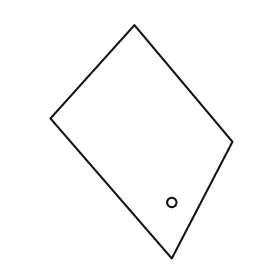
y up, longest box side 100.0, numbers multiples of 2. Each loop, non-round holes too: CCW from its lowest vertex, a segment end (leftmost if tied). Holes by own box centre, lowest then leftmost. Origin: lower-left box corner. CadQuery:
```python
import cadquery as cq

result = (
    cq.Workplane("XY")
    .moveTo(52.0, 0.0)
    .lineTo(78.0, 50.0)
    .lineTo(36.0, 100.0)
    .lineTo(0.0, 60.0)
    .close()
    .moveTo(52.0, 24.0)
    .circle(2.0)
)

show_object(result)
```